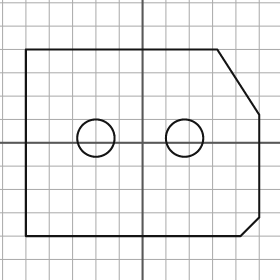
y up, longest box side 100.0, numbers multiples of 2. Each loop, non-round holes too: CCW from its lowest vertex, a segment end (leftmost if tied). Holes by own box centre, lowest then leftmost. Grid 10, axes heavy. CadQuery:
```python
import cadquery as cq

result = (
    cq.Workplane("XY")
    .moveTo(-50.0, -40.0)
    .lineTo(42.0, -40.0)
    .lineTo(50.0, -32.0)
    .lineTo(50.0, 12.0)
    .lineTo(32.0, 40.0)
    .lineTo(-50.0, 40.0)
    .close()
    .moveTo(-20.0, 2.0)
    .circle(8.0)
    .moveTo(18.0, 2.0)
    .circle(8.0)
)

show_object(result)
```